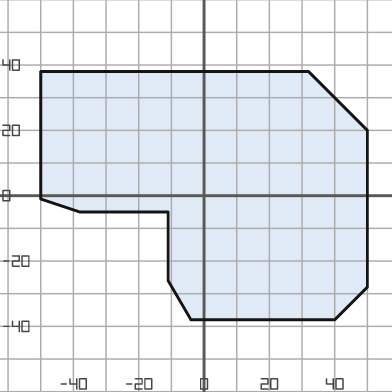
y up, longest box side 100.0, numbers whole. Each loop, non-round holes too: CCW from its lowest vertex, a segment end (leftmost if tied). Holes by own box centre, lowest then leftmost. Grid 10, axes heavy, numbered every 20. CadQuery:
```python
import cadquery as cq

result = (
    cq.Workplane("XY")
    .moveTo(-4.0, -38.0)
    .lineTo(40.0, -38.0)
    .lineTo(50.0, -28.0)
    .lineTo(50.0, 20.0)
    .lineTo(32.0, 38.0)
    .lineTo(-50.0, 38.0)
    .lineTo(-50.0, -1.0)
    .lineTo(-38.0, -5.0)
    .lineTo(-11.0, -5.0)
    .lineTo(-11.0, -26.0)
    .close()
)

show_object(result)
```